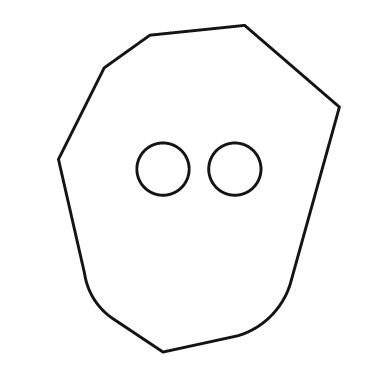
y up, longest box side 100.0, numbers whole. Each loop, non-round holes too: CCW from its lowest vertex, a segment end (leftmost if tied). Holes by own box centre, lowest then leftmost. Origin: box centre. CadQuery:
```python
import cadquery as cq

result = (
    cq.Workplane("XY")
    .moveTo(-11.0, -50.0)
    .lineTo(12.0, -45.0)
    .threePointArc((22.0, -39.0), (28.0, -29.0))
    .lineTo(43.0, 25.0)
    .lineTo(14.0, 50.0)
    .lineTo(-15.0, 47.0)
    .lineTo(-29.0, 37.0)
    .lineTo(-43.0, 9.0)
    .lineTo(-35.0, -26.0)
    .threePointArc((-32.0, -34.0), (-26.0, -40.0))
    .close()
    .moveTo(-11.0, 6.0)
    .circle(8.0)
    .moveTo(11.0, 6.0)
    .circle(8.0)
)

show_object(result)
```